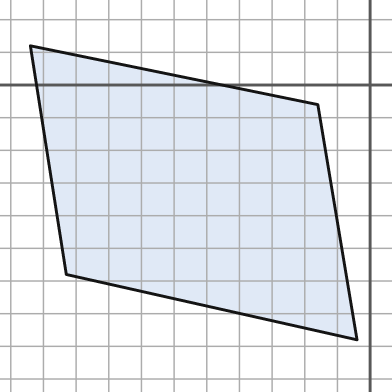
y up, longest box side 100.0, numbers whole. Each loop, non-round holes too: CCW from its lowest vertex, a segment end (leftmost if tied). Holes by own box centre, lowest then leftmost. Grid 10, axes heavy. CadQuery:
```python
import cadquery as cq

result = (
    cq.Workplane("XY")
    .moveTo(-4.0, -78.0)
    .lineTo(-16.0, -6.0)
    .lineTo(-104.0, 12.0)
    .lineTo(-93.0, -58.0)
    .close()
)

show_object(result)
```